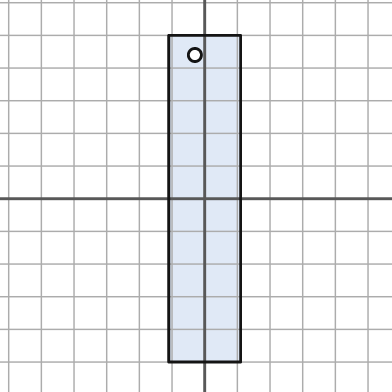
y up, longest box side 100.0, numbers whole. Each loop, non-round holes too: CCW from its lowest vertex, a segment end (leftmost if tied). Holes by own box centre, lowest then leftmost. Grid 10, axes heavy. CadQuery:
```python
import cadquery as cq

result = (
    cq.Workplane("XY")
    .moveTo(-11.0, -50.0)
    .lineTo(11.0, -50.0)
    .lineTo(11.0, 50.0)
    .lineTo(-11.0, 50.0)
    .close()
    .moveTo(-3.0, 44.0)
    .circle(2.0)
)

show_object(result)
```